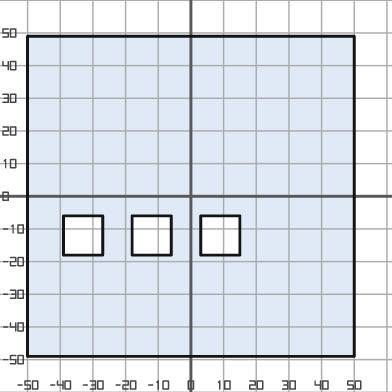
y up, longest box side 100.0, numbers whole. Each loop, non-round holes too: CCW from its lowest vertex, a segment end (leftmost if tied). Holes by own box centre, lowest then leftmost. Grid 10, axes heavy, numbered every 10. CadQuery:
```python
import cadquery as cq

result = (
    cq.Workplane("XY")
    .moveTo(-50.0, -49.0)
    .lineTo(50.0, -49.0)
    .lineTo(50.0, 49.0)
    .lineTo(-50.0, 49.0)
    .close()
    .moveTo(-39.0, -18.0)
    .lineTo(-27.0, -18.0)
    .lineTo(-27.0, -6.0)
    .lineTo(-39.0, -6.0)
    .close()
    .moveTo(-18.0, -18.0)
    .lineTo(-6.0, -18.0)
    .lineTo(-6.0, -6.0)
    .lineTo(-18.0, -6.0)
    .close()
    .moveTo(3.0, -18.0)
    .lineTo(15.0, -18.0)
    .lineTo(15.0, -6.0)
    .lineTo(3.0, -6.0)
    .close()
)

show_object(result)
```